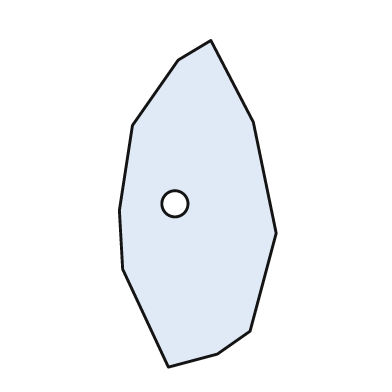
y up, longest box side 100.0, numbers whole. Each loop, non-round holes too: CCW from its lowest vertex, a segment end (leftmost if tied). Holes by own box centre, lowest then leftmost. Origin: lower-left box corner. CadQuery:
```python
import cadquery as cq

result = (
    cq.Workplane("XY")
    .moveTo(15.0, 0.0)
    .lineTo(30.0, 4.0)
    .lineTo(40.0, 11.0)
    .lineTo(48.0, 41.0)
    .lineTo(41.0, 75.0)
    .lineTo(28.0, 100.0)
    .lineTo(18.0, 94.0)
    .lineTo(4.0, 74.0)
    .lineTo(0.0, 48.0)
    .lineTo(1.0, 30.0)
    .close()
    .moveTo(17.0, 50.0)
    .circle(4.0)
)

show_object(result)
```